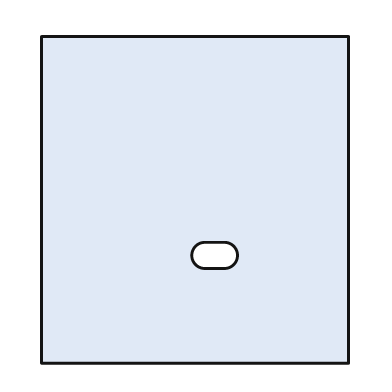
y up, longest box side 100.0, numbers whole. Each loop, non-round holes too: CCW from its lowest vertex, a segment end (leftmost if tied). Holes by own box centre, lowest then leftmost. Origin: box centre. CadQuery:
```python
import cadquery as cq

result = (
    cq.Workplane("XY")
    .moveTo(-47.0, -50.0)
    .lineTo(47.0, -50.0)
    .lineTo(47.0, 50.0)
    .lineTo(-47.0, 50.0)
    .close()
    .moveTo(3.0, -21.0)
    .lineTo(9.0, -21.0)
    .threePointArc((13.0, -17.0), (9.0, -13.0))
    .lineTo(3.0, -13.0)
    .threePointArc((-1.0, -17.0), (3.0, -21.0))
    .close()
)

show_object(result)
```